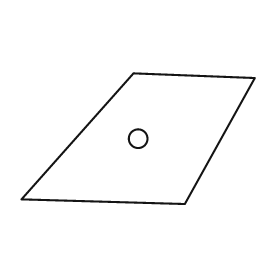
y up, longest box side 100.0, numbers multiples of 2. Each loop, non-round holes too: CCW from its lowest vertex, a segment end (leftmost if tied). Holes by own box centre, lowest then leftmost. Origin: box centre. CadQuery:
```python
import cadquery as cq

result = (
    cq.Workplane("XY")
    .moveTo(20.0, -28.0)
    .lineTo(50.0, 26.0)
    .lineTo(-2.0, 28.0)
    .lineTo(-50.0, -26.0)
    .close()
    .moveTo(0.0, 0.0)
    .circle(4.0)
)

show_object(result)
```